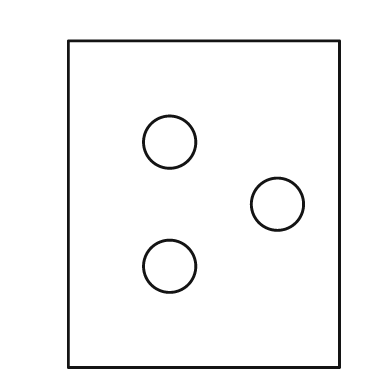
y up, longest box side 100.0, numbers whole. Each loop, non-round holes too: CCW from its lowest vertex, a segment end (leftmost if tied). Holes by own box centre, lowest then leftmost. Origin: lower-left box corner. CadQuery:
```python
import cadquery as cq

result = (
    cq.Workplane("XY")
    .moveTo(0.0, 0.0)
    .lineTo(83.0, 0.0)
    .lineTo(83.0, 100.0)
    .lineTo(0.0, 100.0)
    .close()
    .moveTo(31.0, 31.0)
    .circle(8.0)
    .moveTo(64.0, 50.0)
    .circle(8.0)
    .moveTo(31.0, 69.0)
    .circle(8.0)
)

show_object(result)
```